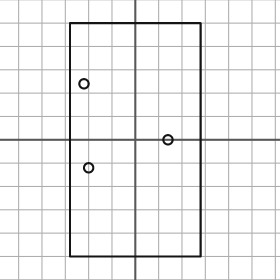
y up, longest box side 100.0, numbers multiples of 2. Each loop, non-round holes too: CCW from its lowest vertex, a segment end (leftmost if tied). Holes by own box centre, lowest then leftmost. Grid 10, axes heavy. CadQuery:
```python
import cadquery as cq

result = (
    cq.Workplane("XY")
    .moveTo(-28.0, -50.0)
    .lineTo(28.0, -50.0)
    .lineTo(28.0, 50.0)
    .lineTo(-28.0, 50.0)
    .close()
    .moveTo(-20.0, -12.0)
    .circle(2.0)
    .moveTo(14.0, 0.0)
    .circle(2.0)
    .moveTo(-22.0, 24.0)
    .circle(2.0)
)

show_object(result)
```